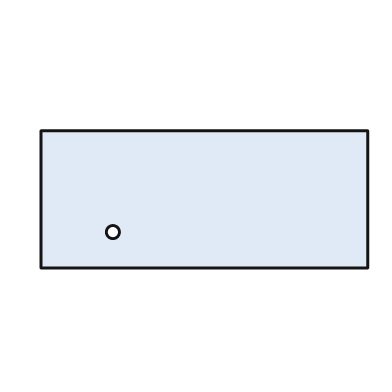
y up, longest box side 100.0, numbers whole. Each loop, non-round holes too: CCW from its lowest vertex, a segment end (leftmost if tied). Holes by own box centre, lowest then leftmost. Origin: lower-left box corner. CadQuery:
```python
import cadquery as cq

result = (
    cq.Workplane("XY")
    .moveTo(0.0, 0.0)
    .lineTo(100.0, 0.0)
    .lineTo(100.0, 42.0)
    .lineTo(0.0, 42.0)
    .close()
    .moveTo(22.0, 11.0)
    .circle(2.0)
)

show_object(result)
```